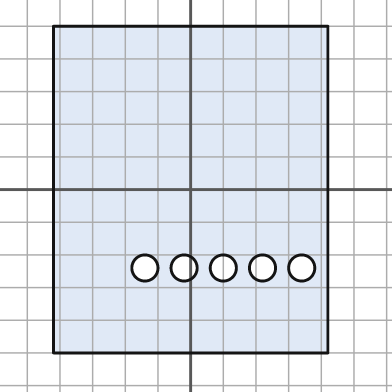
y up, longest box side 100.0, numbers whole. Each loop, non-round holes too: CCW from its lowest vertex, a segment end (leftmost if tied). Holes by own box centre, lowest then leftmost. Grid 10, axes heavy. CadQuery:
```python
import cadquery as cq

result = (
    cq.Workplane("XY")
    .moveTo(-42.0, -50.0)
    .lineTo(42.0, -50.0)
    .lineTo(42.0, 50.0)
    .lineTo(-42.0, 50.0)
    .close()
    .moveTo(-14.0, -24.0)
    .circle(4.0)
    .moveTo(-2.0, -24.0)
    .circle(4.0)
    .moveTo(10.0, -24.0)
    .circle(4.0)
    .moveTo(22.0, -24.0)
    .circle(4.0)
    .moveTo(34.0, -24.0)
    .circle(4.0)
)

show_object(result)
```